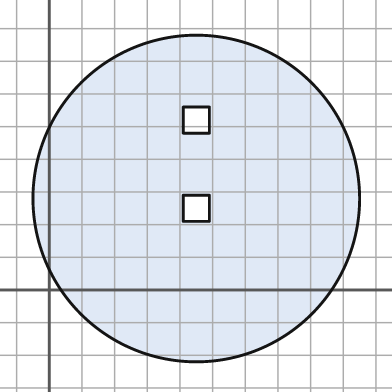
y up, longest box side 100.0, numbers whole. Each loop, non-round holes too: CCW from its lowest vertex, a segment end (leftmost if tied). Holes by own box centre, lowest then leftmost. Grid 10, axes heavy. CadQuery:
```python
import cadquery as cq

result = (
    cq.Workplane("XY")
    .moveTo(45.0, 28.0)
    .circle(50.0)
    .moveTo(41.0, 21.0)
    .lineTo(49.0, 21.0)
    .lineTo(49.0, 29.0)
    .lineTo(41.0, 29.0)
    .close()
    .moveTo(41.0, 48.0)
    .lineTo(49.0, 48.0)
    .lineTo(49.0, 56.0)
    .lineTo(41.0, 56.0)
    .close()
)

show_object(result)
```